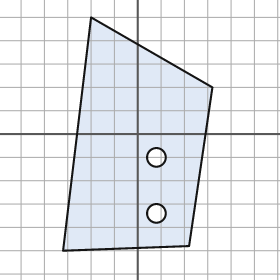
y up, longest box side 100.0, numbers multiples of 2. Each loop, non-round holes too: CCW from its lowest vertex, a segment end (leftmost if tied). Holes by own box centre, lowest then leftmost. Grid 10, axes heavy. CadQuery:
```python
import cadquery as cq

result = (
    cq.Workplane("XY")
    .moveTo(-32.0, -50.0)
    .lineTo(22.0, -48.0)
    .lineTo(32.0, 20.0)
    .lineTo(-20.0, 50.0)
    .close()
    .moveTo(8.0, -34.0)
    .circle(4.0)
    .moveTo(8.0, -10.0)
    .circle(4.0)
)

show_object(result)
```